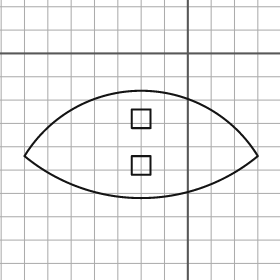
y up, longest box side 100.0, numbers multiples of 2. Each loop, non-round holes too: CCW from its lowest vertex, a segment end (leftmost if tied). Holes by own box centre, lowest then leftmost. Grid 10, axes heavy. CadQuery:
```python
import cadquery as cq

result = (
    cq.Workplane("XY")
    .moveTo(-70.0, -44.0)
    .threePointArc((-20.0, -62.0), (30.0, -44.0))
    .threePointArc((-20.0, -16.0), (-70.0, -44.0))
    .close()
    .moveTo(-24.0, -52.0)
    .lineTo(-16.0, -52.0)
    .lineTo(-16.0, -44.0)
    .lineTo(-24.0, -44.0)
    .close()
    .moveTo(-24.0, -32.0)
    .lineTo(-16.0, -32.0)
    .lineTo(-16.0, -24.0)
    .lineTo(-24.0, -24.0)
    .close()
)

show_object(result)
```